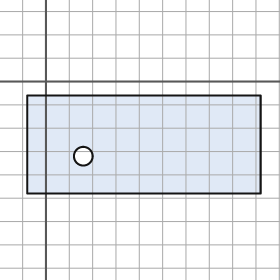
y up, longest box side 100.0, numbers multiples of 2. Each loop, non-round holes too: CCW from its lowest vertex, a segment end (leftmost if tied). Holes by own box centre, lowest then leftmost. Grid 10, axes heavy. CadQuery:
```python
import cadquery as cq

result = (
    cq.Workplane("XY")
    .moveTo(-8.0, -48.0)
    .lineTo(92.0, -48.0)
    .lineTo(92.0, -6.0)
    .lineTo(-8.0, -6.0)
    .close()
    .moveTo(16.0, -32.0)
    .circle(4.0)
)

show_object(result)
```